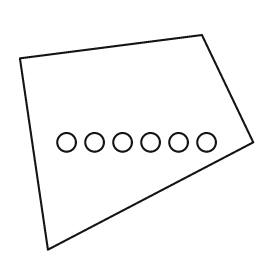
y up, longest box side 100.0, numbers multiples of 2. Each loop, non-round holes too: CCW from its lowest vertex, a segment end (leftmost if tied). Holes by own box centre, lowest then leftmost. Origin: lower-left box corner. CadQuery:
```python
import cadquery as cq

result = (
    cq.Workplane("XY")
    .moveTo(12.0, 0.0)
    .lineTo(100.0, 46.0)
    .lineTo(78.0, 92.0)
    .lineTo(0.0, 82.0)
    .close()
    .moveTo(20.0, 46.0)
    .circle(4.0)
    .moveTo(32.0, 46.0)
    .circle(4.0)
    .moveTo(44.0, 46.0)
    .circle(4.0)
    .moveTo(56.0, 46.0)
    .circle(4.0)
    .moveTo(68.0, 46.0)
    .circle(4.0)
    .moveTo(80.0, 46.0)
    .circle(4.0)
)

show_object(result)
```